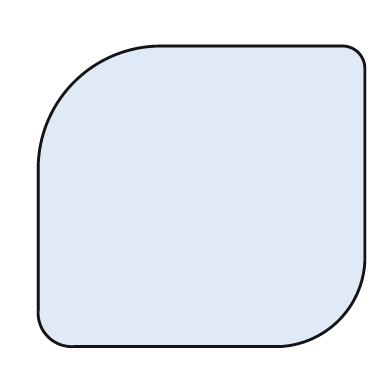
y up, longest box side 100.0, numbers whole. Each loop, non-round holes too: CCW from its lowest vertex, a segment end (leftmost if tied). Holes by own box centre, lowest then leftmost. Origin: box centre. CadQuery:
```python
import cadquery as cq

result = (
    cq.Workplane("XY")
    .moveTo(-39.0, -46.0)
    .lineTo(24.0, -46.0)
    .threePointArc((42.0, -38.0), (50.0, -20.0))
    .lineTo(50.0, 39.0)
    .threePointArc((48.0, 44.0), (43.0, 46.0))
    .lineTo(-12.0, 46.0)
    .threePointArc((-39.0, 35.0), (-50.0, 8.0))
    .lineTo(-50.0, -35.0)
    .threePointArc((-47.0, -43.0), (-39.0, -46.0))
    .close()
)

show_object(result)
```